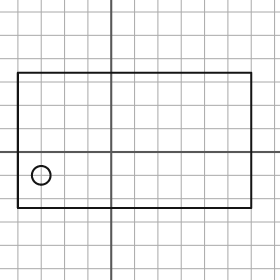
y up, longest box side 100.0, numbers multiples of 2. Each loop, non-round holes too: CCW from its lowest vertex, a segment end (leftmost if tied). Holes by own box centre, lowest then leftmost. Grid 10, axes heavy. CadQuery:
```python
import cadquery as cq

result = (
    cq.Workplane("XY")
    .moveTo(-40.0, -24.0)
    .lineTo(60.0, -24.0)
    .lineTo(60.0, 34.0)
    .lineTo(-40.0, 34.0)
    .close()
    .moveTo(-30.0, -10.0)
    .circle(4.0)
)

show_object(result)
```